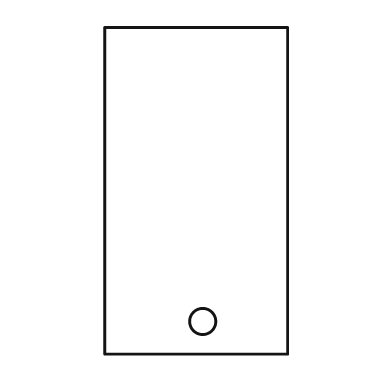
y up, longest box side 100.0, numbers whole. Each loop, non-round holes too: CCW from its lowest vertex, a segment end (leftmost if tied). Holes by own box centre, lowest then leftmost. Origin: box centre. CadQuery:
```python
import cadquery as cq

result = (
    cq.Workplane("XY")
    .moveTo(-28.0, -50.0)
    .lineTo(28.0, -50.0)
    .lineTo(28.0, 50.0)
    .lineTo(-28.0, 50.0)
    .close()
    .moveTo(2.0, -40.0)
    .circle(4.0)
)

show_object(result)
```